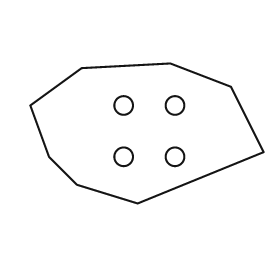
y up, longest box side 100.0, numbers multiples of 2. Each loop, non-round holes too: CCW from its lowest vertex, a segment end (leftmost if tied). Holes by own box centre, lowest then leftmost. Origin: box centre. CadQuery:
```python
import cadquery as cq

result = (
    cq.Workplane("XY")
    .moveTo(-4.0, -30.0)
    .lineTo(50.0, -8.0)
    .lineTo(36.0, 20.0)
    .lineTo(10.0, 30.0)
    .lineTo(-28.0, 28.0)
    .lineTo(-50.0, 12.0)
    .lineTo(-42.0, -10.0)
    .lineTo(-30.0, -22.0)
    .close()
    .moveTo(-10.0, -10.0)
    .circle(4.0)
    .moveTo(12.0, -10.0)
    .circle(4.0)
    .moveTo(-10.0, 12.0)
    .circle(4.0)
    .moveTo(12.0, 12.0)
    .circle(4.0)
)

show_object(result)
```